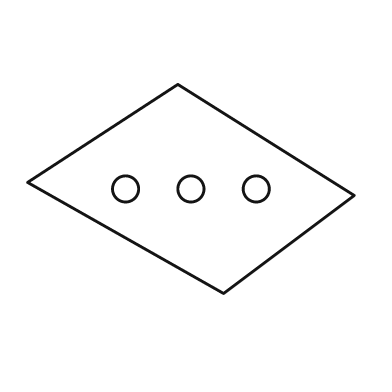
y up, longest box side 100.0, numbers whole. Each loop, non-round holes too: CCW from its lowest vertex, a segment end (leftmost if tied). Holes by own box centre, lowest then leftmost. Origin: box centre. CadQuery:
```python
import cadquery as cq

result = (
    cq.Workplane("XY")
    .moveTo(10.0, -32.0)
    .lineTo(50.0, -2.0)
    .lineTo(-4.0, 32.0)
    .lineTo(-50.0, 2.0)
    .close()
    .moveTo(-20.0, 0.0)
    .circle(4.0)
    .moveTo(0.0, 0.0)
    .circle(4.0)
    .moveTo(20.0, 0.0)
    .circle(4.0)
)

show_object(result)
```